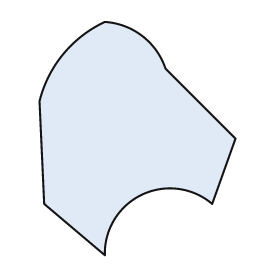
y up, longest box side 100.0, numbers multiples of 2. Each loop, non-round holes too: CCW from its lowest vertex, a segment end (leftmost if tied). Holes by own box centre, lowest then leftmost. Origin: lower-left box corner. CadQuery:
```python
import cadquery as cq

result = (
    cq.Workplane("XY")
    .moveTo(28.0, 0.0)
    .threePointArc((44.0, 26.0), (74.0, 22.0))
    .lineTo(84.0, 50.0)
    .lineTo(54.0, 80.0)
    .threePointArc((44.0, 94.0), (28.0, 100.0))
    .threePointArc((10.0, 86.0), (0.0, 66.0))
    .lineTo(2.0, 22.0)
    .close()
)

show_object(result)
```